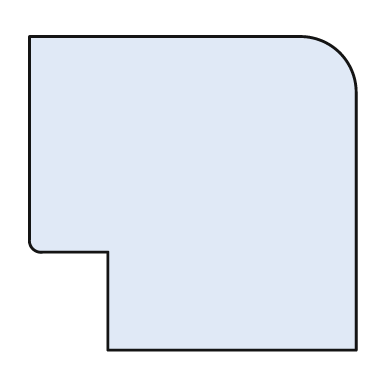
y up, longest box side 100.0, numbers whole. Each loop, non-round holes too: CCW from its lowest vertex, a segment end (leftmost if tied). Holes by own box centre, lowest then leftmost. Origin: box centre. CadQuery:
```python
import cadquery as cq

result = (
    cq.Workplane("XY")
    .moveTo(-26.0, -48.0)
    .lineTo(50.0, -48.0)
    .lineTo(50.0, 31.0)
    .threePointArc((45.0, 43.0), (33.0, 48.0))
    .lineTo(-50.0, 48.0)
    .lineTo(-50.0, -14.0)
    .threePointArc((-49.0, -17.0), (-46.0, -18.0))
    .lineTo(-26.0, -18.0)
    .close()
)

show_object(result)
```